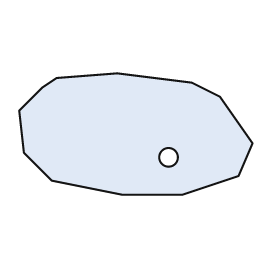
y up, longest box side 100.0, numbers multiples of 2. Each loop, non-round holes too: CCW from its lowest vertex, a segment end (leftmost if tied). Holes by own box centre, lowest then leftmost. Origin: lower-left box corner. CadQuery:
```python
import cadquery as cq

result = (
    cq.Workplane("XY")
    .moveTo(44.0, 0.0)
    .lineTo(70.0, 0.0)
    .lineTo(94.0, 8.0)
    .lineTo(100.0, 22.0)
    .lineTo(86.0, 42.0)
    .lineTo(74.0, 48.0)
    .lineTo(42.0, 52.0)
    .lineTo(16.0, 50.0)
    .lineTo(10.0, 46.0)
    .lineTo(0.0, 36.0)
    .lineTo(2.0, 18.0)
    .lineTo(14.0, 6.0)
    .close()
    .moveTo(64.0, 16.0)
    .circle(4.0)
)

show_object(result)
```